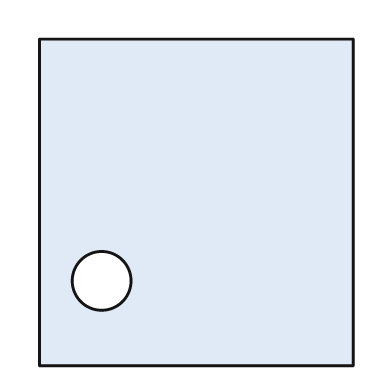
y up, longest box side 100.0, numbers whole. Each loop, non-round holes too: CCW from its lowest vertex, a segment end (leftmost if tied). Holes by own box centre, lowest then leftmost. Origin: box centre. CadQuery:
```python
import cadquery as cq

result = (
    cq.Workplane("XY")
    .moveTo(-48.0, -50.0)
    .lineTo(48.0, -50.0)
    .lineTo(48.0, 50.0)
    .lineTo(-48.0, 50.0)
    .close()
    .moveTo(-29.0, -24.0)
    .circle(9.0)
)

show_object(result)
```